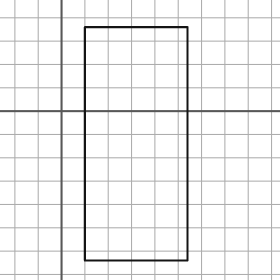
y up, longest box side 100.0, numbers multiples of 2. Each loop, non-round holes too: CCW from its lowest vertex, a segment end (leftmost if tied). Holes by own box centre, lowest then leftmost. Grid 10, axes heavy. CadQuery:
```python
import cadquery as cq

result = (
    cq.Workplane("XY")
    .moveTo(10.0, -64.0)
    .lineTo(54.0, -64.0)
    .lineTo(54.0, 36.0)
    .lineTo(10.0, 36.0)
    .close()
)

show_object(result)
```